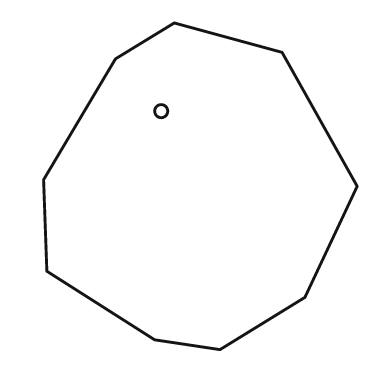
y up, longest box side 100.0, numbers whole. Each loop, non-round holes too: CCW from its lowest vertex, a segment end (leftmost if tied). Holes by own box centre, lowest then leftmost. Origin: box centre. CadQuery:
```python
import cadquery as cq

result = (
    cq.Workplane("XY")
    .moveTo(6.0, -50.0)
    .lineTo(32.0, -34.0)
    .lineTo(48.0, 0.0)
    .lineTo(25.0, 41.0)
    .lineTo(-8.0, 50.0)
    .lineTo(-26.0, 39.0)
    .lineTo(-48.0, 2.0)
    .lineTo(-47.0, -26.0)
    .lineTo(-14.0, -47.0)
    .close()
    .moveTo(-12.0, 23.0)
    .circle(2.0)
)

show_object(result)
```